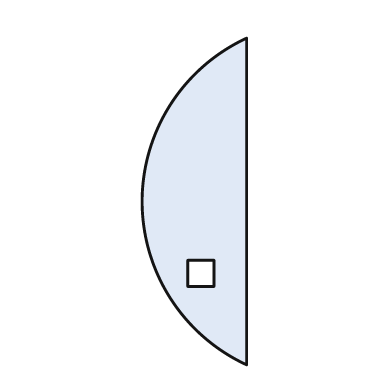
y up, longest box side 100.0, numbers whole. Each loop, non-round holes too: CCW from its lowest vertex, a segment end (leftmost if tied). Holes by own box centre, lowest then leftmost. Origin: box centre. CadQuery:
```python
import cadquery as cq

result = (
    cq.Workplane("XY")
    .moveTo(16.0, -50.0)
    .lineTo(16.0, 50.0)
    .threePointArc((-16.0, 0.0), (16.0, -50.0))
    .close()
    .moveTo(-2.0, -26.0)
    .lineTo(6.0, -26.0)
    .lineTo(6.0, -18.0)
    .lineTo(-2.0, -18.0)
    .close()
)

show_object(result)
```